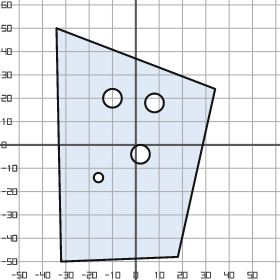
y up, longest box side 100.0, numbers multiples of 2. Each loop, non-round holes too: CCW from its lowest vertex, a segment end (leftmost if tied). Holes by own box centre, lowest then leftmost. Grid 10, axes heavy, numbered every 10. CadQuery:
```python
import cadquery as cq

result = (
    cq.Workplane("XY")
    .moveTo(-32.0, -50.0)
    .lineTo(18.0, -48.0)
    .lineTo(34.0, 24.0)
    .lineTo(-34.0, 50.0)
    .close()
    .moveTo(-16.0, -14.0)
    .circle(2.0)
    .moveTo(2.0, -4.0)
    .circle(4.0)
    .moveTo(8.0, 18.0)
    .circle(4.0)
    .moveTo(-10.0, 20.0)
    .circle(4.0)
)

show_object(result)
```